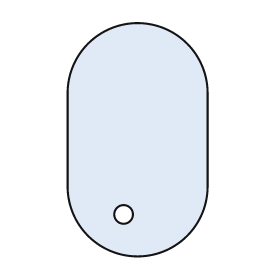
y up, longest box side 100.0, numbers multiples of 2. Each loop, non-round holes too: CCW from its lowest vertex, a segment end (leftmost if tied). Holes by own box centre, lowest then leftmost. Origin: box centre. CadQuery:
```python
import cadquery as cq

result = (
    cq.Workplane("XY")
    .moveTo(-30.0, -20.0)
    .threePointArc((0.0, -50.0), (30.0, -20.0))
    .lineTo(30.0, 20.0)
    .threePointArc((0.0, 50.0), (-30.0, 20.0))
    .close()
    .moveTo(-6.0, -32.0)
    .circle(4.0)
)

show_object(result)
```